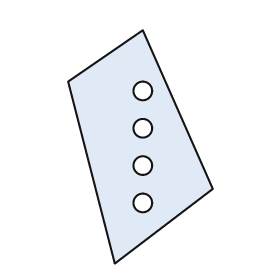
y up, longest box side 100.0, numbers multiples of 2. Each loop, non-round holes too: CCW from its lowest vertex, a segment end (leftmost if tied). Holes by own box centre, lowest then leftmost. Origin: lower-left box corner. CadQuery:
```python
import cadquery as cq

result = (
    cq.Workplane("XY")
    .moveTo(20.0, 0.0)
    .lineTo(62.0, 32.0)
    .lineTo(32.0, 100.0)
    .lineTo(0.0, 78.0)
    .close()
    .moveTo(32.0, 26.0)
    .circle(4.0)
    .moveTo(32.0, 42.0)
    .circle(4.0)
    .moveTo(32.0, 58.0)
    .circle(4.0)
    .moveTo(32.0, 74.0)
    .circle(4.0)
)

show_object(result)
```